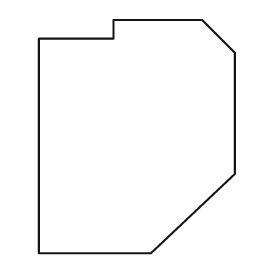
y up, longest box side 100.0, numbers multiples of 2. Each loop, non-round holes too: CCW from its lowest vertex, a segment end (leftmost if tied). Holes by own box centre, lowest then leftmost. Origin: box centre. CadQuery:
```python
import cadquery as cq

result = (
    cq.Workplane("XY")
    .moveTo(-42.0, -50.0)
    .lineTo(6.0, -50.0)
    .lineTo(42.0, -16.0)
    .lineTo(42.0, 36.0)
    .lineTo(28.0, 50.0)
    .lineTo(-10.0, 50.0)
    .lineTo(-10.0, 42.0)
    .lineTo(-42.0, 42.0)
    .close()
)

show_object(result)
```